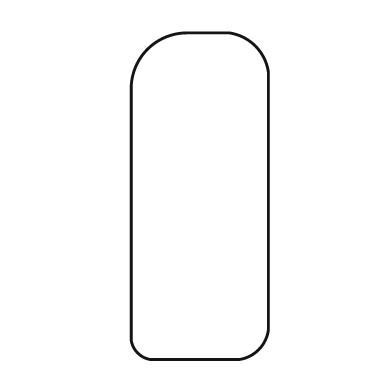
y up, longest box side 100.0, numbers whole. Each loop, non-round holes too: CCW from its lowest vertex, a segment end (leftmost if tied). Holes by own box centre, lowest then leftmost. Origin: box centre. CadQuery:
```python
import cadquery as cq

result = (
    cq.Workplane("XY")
    .moveTo(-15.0, -50.0)
    .lineTo(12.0, -50.0)
    .threePointArc((18.0, -47.0), (21.0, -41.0))
    .lineTo(21.0, 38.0)
    .threePointArc((17.0, 46.0), (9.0, 50.0))
    .lineTo(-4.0, 50.0)
    .threePointArc((-16.0, 45.0), (-21.0, 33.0))
    .lineTo(-21.0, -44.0)
    .threePointArc((-19.0, -48.0), (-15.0, -50.0))
    .close()
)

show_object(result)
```